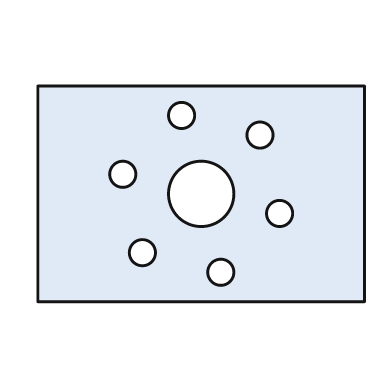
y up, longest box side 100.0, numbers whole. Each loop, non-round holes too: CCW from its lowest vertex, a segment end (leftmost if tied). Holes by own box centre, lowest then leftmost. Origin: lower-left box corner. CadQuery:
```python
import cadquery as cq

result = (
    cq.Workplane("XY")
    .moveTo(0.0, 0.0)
    .lineTo(100.0, 0.0)
    .lineTo(100.0, 66.0)
    .lineTo(0.0, 66.0)
    .close()
    .moveTo(56.0, 9.0)
    .circle(4.0)
    .moveTo(32.0, 15.0)
    .circle(4.0)
    .moveTo(74.0, 27.0)
    .circle(4.0)
    .moveTo(50.0, 33.0)
    .circle(10.0)
    .moveTo(26.0, 39.0)
    .circle(4.0)
    .moveTo(68.0, 51.0)
    .circle(4.0)
    .moveTo(44.0, 57.0)
    .circle(4.0)
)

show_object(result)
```